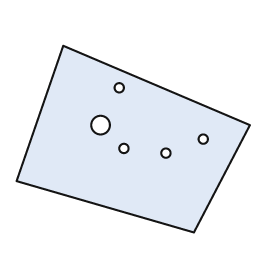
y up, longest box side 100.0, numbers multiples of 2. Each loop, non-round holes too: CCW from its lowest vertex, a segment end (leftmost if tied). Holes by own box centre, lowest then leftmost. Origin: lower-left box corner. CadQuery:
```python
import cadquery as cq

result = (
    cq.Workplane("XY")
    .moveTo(76.0, 0.0)
    .lineTo(100.0, 46.0)
    .lineTo(20.0, 80.0)
    .lineTo(0.0, 22.0)
    .close()
    .moveTo(64.0, 34.0)
    .circle(2.0)
    .moveTo(46.0, 36.0)
    .circle(2.0)
    .moveTo(80.0, 40.0)
    .circle(2.0)
    .moveTo(36.0, 46.0)
    .circle(4.0)
    .moveTo(44.0, 62.0)
    .circle(2.0)
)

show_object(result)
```